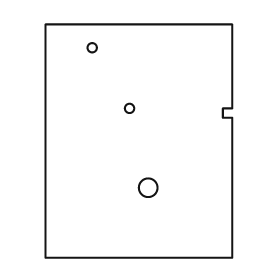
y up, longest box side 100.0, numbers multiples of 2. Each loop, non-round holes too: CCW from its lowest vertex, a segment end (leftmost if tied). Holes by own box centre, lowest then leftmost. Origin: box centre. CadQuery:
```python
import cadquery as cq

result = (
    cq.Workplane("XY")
    .moveTo(-40.0, -50.0)
    .lineTo(40.0, -50.0)
    .lineTo(40.0, 10.0)
    .lineTo(36.0, 10.0)
    .lineTo(36.0, 14.0)
    .lineTo(40.0, 14.0)
    .lineTo(40.0, 50.0)
    .lineTo(-40.0, 50.0)
    .close()
    .moveTo(4.0, -20.0)
    .circle(4.0)
    .moveTo(-4.0, 14.0)
    .circle(2.0)
    .moveTo(-20.0, 40.0)
    .circle(2.0)
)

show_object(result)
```